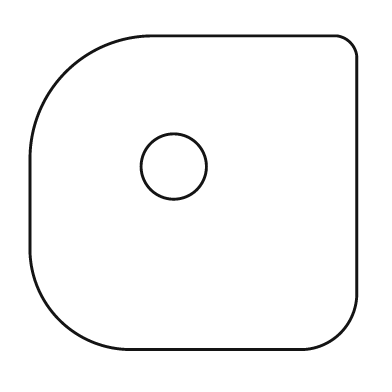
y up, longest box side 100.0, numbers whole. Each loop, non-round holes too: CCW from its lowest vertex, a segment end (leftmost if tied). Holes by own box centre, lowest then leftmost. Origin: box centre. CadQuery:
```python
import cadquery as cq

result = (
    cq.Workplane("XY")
    .moveTo(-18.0, -48.0)
    .lineTo(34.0, -48.0)
    .threePointArc((45.0, -43.0), (50.0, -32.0))
    .lineTo(50.0, 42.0)
    .threePointArc((48.0, 46.0), (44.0, 48.0))
    .lineTo(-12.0, 48.0)
    .threePointArc((-39.0, 37.0), (-50.0, 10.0))
    .lineTo(-50.0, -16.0)
    .threePointArc((-41.0, -39.0), (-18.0, -48.0))
    .close()
    .moveTo(-6.0, 8.0)
    .circle(10.0)
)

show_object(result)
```